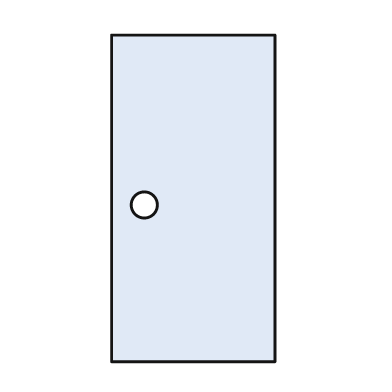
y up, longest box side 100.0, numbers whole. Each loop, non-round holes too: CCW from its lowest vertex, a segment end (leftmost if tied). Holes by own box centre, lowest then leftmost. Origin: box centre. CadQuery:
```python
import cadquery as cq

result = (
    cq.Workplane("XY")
    .moveTo(-25.0, -50.0)
    .lineTo(25.0, -50.0)
    .lineTo(25.0, 50.0)
    .lineTo(-25.0, 50.0)
    .close()
    .moveTo(-15.0, -2.0)
    .circle(4.0)
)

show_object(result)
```